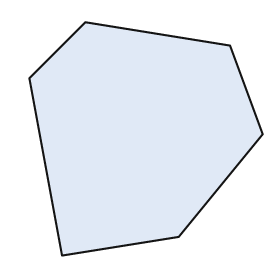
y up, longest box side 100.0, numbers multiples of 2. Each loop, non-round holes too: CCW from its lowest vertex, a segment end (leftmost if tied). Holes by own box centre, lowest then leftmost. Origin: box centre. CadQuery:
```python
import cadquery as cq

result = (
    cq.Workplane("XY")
    .moveTo(-36.0, -50.0)
    .lineTo(14.0, -42.0)
    .lineTo(50.0, 2.0)
    .lineTo(36.0, 40.0)
    .lineTo(-26.0, 50.0)
    .lineTo(-50.0, 26.0)
    .close()
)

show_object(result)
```